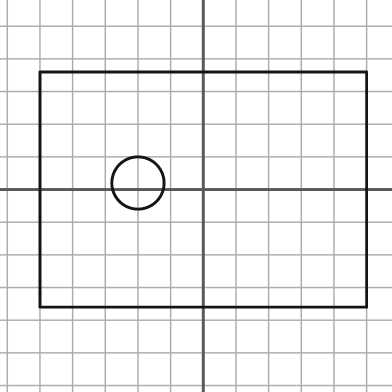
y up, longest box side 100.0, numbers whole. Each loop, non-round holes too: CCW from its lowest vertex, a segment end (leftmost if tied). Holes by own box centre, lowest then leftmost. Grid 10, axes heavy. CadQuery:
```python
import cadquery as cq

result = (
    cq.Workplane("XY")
    .moveTo(-50.0, -36.0)
    .lineTo(50.0, -36.0)
    .lineTo(50.0, 36.0)
    .lineTo(-50.0, 36.0)
    .close()
    .moveTo(-20.0, 2.0)
    .circle(8.0)
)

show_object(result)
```